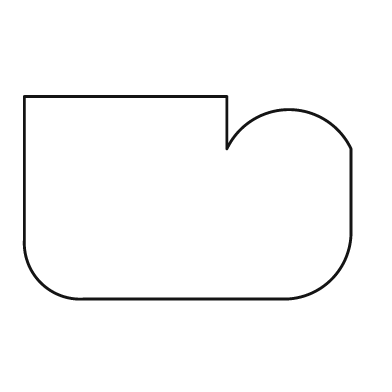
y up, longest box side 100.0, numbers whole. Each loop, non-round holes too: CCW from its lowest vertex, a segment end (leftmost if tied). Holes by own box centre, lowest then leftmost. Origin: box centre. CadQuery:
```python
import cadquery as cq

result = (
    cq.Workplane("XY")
    .moveTo(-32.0, -31.0)
    .lineTo(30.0, -31.0)
    .threePointArc((44.0, -25.0), (50.0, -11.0))
    .lineTo(50.0, 15.0)
    .threePointArc((31.0, 27.0), (12.0, 15.0))
    .lineTo(12.0, 31.0)
    .lineTo(-50.0, 31.0)
    .lineTo(-50.0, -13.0)
    .threePointArc((-45.0, -26.0), (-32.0, -31.0))
    .close()
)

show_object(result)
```